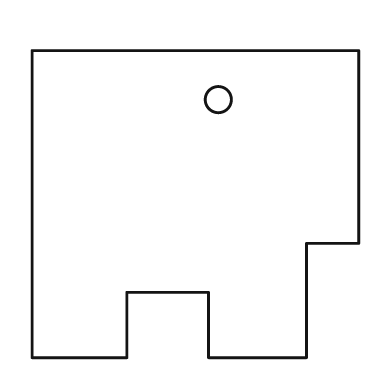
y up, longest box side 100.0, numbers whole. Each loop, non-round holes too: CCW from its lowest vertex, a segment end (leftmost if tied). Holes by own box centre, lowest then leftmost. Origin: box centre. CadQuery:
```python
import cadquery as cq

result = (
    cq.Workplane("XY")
    .moveTo(-50.0, -47.0)
    .lineTo(-21.0, -47.0)
    .lineTo(-21.0, -27.0)
    .lineTo(4.0, -27.0)
    .lineTo(4.0, -47.0)
    .lineTo(34.0, -47.0)
    .lineTo(34.0, -12.0)
    .lineTo(50.0, -12.0)
    .lineTo(50.0, 47.0)
    .lineTo(-50.0, 47.0)
    .close()
    .moveTo(7.0, 32.0)
    .circle(4.0)
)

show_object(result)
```